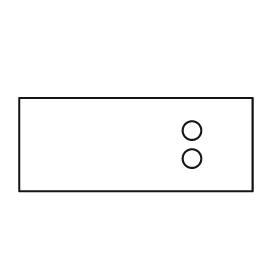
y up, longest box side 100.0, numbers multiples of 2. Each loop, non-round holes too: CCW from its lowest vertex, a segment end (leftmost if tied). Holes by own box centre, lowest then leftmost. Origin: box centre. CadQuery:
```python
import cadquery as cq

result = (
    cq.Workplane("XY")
    .moveTo(-50.0, -20.0)
    .lineTo(50.0, -20.0)
    .lineTo(50.0, 20.0)
    .lineTo(-50.0, 20.0)
    .close()
    .moveTo(24.0, -6.0)
    .circle(4.0)
    .moveTo(24.0, 6.0)
    .circle(4.0)
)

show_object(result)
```